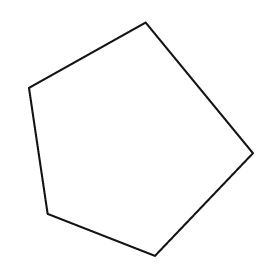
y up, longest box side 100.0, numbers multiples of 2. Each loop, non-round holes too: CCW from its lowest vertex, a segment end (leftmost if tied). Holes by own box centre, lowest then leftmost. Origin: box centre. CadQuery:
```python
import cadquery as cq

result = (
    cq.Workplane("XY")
    .moveTo(6.0, -50.0)
    .lineTo(48.0, -6.0)
    .lineTo(2.0, 50.0)
    .lineTo(-48.0, 22.0)
    .lineTo(-40.0, -32.0)
    .close()
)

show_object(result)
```